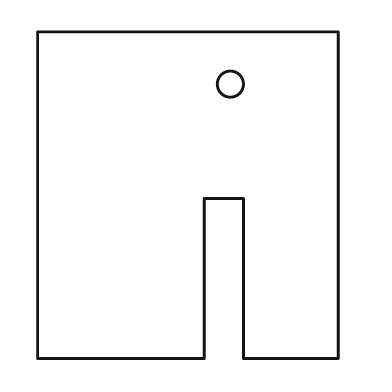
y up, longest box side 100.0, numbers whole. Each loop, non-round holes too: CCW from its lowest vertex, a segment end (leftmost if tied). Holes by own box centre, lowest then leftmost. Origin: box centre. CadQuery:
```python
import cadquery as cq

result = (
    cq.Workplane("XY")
    .moveTo(-46.0, -50.0)
    .lineTo(5.0, -50.0)
    .lineTo(5.0, -1.0)
    .lineTo(17.0, -1.0)
    .lineTo(17.0, -50.0)
    .lineTo(46.0, -50.0)
    .lineTo(46.0, 50.0)
    .lineTo(-46.0, 50.0)
    .close()
    .moveTo(13.0, 34.0)
    .circle(4.0)
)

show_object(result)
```